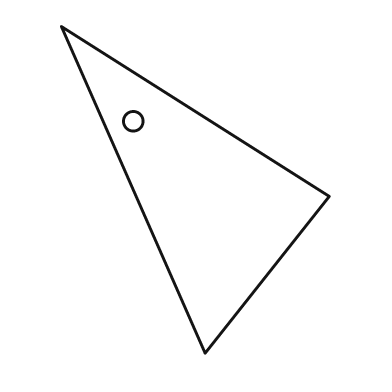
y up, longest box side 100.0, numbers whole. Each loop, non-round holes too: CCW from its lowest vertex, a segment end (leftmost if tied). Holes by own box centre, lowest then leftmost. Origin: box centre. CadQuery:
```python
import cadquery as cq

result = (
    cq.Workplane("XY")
    .moveTo(3.0, -50.0)
    .lineTo(41.0, -2.0)
    .lineTo(-41.0, 50.0)
    .close()
    .moveTo(-19.0, 21.0)
    .circle(3.0)
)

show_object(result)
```